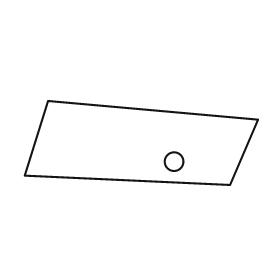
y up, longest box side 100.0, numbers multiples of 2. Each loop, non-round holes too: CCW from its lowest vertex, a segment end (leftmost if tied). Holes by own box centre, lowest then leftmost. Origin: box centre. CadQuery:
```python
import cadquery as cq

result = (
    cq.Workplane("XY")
    .moveTo(38.0, -18.0)
    .lineTo(50.0, 10.0)
    .lineTo(-40.0, 18.0)
    .lineTo(-50.0, -14.0)
    .close()
    .moveTo(14.0, -8.0)
    .circle(4.0)
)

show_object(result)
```